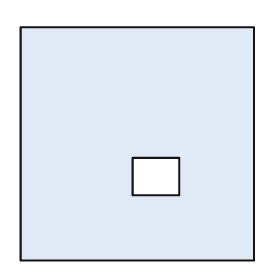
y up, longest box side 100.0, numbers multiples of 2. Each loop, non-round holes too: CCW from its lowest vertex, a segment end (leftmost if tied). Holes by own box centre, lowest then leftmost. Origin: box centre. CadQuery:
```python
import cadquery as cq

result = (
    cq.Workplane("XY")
    .moveTo(-50.0, -50.0)
    .lineTo(50.0, -50.0)
    .lineTo(50.0, 50.0)
    .lineTo(-50.0, 50.0)
    .close()
    .moveTo(-2.0, -22.0)
    .lineTo(18.0, -22.0)
    .lineTo(18.0, -6.0)
    .lineTo(-2.0, -6.0)
    .close()
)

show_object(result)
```